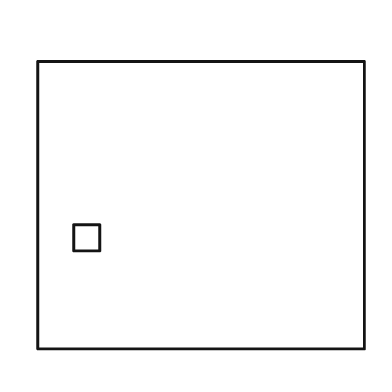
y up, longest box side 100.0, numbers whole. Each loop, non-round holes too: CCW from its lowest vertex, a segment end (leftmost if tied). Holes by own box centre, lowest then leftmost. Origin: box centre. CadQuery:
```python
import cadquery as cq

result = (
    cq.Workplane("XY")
    .moveTo(-50.0, -44.0)
    .lineTo(50.0, -44.0)
    .lineTo(50.0, 44.0)
    .lineTo(-50.0, 44.0)
    .close()
    .moveTo(-39.0, -14.0)
    .lineTo(-31.0, -14.0)
    .lineTo(-31.0, -6.0)
    .lineTo(-39.0, -6.0)
    .close()
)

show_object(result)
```